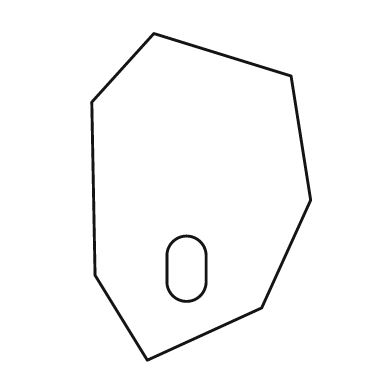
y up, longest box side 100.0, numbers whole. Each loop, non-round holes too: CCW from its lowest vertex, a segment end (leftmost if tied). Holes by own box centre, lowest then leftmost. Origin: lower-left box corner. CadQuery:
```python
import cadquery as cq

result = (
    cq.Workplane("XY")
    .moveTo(17.0, 0.0)
    .lineTo(52.0, 16.0)
    .lineTo(67.0, 49.0)
    .lineTo(61.0, 87.0)
    .lineTo(19.0, 100.0)
    .lineTo(0.0, 79.0)
    .lineTo(1.0, 26.0)
    .close()
    .moveTo(23.0, 24.0)
    .threePointArc((29.0, 18.0), (35.0, 24.0))
    .lineTo(35.0, 32.0)
    .threePointArc((29.0, 38.0), (23.0, 32.0))
    .close()
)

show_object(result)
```